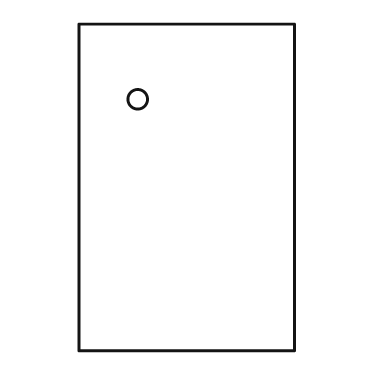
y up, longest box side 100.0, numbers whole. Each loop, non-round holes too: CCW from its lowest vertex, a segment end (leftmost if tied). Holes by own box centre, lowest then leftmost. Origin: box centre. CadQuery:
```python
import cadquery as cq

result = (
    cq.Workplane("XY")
    .moveTo(-33.0, -50.0)
    .lineTo(33.0, -50.0)
    .lineTo(33.0, 50.0)
    .lineTo(-33.0, 50.0)
    .close()
    .moveTo(-15.0, 27.0)
    .circle(3.0)
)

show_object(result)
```